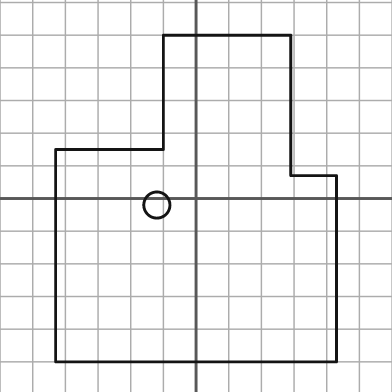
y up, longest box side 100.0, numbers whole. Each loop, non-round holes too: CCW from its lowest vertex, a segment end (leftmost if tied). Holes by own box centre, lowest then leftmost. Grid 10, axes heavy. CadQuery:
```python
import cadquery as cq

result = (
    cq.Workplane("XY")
    .moveTo(-43.0, -50.0)
    .lineTo(43.0, -50.0)
    .lineTo(43.0, 7.0)
    .lineTo(29.0, 7.0)
    .lineTo(29.0, 50.0)
    .lineTo(-10.0, 50.0)
    .lineTo(-10.0, 15.0)
    .lineTo(-43.0, 15.0)
    .close()
    .moveTo(-12.0, -2.0)
    .circle(4.0)
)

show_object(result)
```